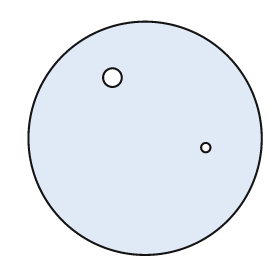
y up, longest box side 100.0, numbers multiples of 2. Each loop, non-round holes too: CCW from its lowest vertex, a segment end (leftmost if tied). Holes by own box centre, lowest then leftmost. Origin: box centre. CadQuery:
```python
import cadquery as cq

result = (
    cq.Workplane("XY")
    .moveTo(0.0, 0.0)
    .circle(50.0)
    .moveTo(26.0, -4.0)
    .circle(2.0)
    .moveTo(-14.0, 26.0)
    .circle(4.0)
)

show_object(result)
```